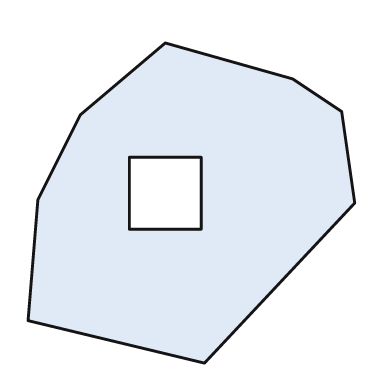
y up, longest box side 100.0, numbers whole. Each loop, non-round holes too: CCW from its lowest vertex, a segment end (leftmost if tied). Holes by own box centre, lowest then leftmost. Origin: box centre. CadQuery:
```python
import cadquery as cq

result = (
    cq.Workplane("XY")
    .moveTo(4.0, -49.0)
    .lineTo(50.0, 0.0)
    .lineTo(46.0, 28.0)
    .lineTo(31.0, 38.0)
    .lineTo(-8.0, 49.0)
    .lineTo(-34.0, 27.0)
    .lineTo(-47.0, 1.0)
    .lineTo(-50.0, -36.0)
    .close()
    .moveTo(-19.0, -8.0)
    .lineTo(3.0, -8.0)
    .lineTo(3.0, 14.0)
    .lineTo(-19.0, 14.0)
    .close()
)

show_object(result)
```